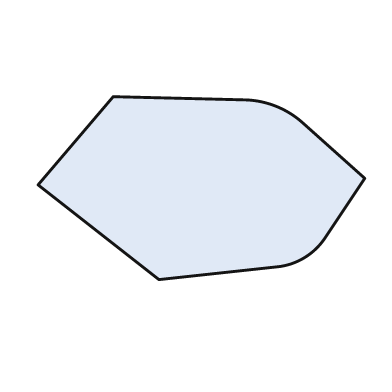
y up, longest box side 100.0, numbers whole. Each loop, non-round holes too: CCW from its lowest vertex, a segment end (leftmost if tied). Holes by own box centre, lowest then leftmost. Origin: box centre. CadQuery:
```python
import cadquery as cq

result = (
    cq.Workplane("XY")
    .moveTo(-13.0, -28.0)
    .lineTo(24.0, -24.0)
    .threePointArc((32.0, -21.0), (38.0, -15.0))
    .lineTo(50.0, 3.0)
    .lineTo(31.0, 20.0)
    .threePointArc((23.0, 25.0), (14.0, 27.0))
    .lineTo(-27.0, 28.0)
    .lineTo(-50.0, 1.0)
    .close()
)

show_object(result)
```